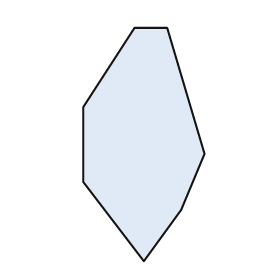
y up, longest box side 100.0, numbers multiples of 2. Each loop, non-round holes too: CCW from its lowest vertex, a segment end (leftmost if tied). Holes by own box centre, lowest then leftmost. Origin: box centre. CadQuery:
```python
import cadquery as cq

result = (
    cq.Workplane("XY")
    .moveTo(0.0, -50.0)
    .lineTo(16.0, -28.0)
    .lineTo(26.0, -4.0)
    .lineTo(10.0, 50.0)
    .lineTo(-4.0, 50.0)
    .lineTo(-26.0, 16.0)
    .lineTo(-26.0, -16.0)
    .close()
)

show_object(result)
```